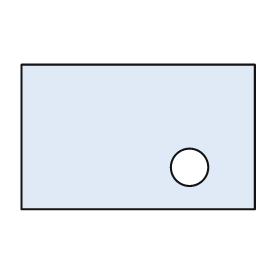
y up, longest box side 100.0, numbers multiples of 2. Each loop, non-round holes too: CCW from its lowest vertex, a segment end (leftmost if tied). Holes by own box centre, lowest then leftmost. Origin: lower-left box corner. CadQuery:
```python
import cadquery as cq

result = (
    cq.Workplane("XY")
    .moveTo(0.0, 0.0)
    .lineTo(100.0, 0.0)
    .lineTo(100.0, 62.0)
    .lineTo(0.0, 62.0)
    .close()
    .moveTo(72.0, 18.0)
    .circle(8.0)
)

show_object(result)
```